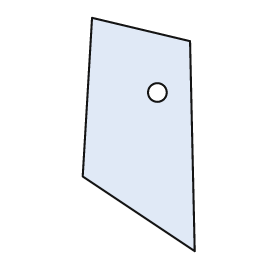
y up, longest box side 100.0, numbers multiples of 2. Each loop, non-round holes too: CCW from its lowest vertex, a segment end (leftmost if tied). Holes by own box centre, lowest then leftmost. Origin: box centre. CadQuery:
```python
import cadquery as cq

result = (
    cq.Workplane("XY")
    .moveTo(24.0, -50.0)
    .lineTo(22.0, 40.0)
    .lineTo(-20.0, 50.0)
    .lineTo(-24.0, -18.0)
    .close()
    .moveTo(8.0, 18.0)
    .circle(4.0)
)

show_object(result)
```